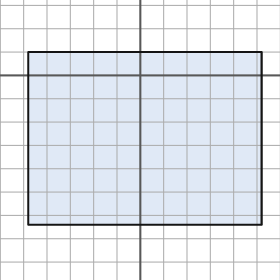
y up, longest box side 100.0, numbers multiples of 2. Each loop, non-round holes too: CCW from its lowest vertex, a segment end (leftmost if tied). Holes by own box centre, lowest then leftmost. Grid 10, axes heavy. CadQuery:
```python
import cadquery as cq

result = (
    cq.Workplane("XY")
    .moveTo(-48.0, -64.0)
    .lineTo(52.0, -64.0)
    .lineTo(52.0, 10.0)
    .lineTo(-48.0, 10.0)
    .close()
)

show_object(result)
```